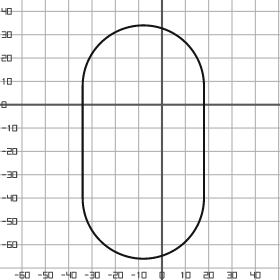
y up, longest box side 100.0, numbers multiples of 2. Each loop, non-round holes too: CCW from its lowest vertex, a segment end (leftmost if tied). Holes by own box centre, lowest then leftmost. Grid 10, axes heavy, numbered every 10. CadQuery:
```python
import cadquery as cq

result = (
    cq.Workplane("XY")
    .moveTo(-34.0, -40.0)
    .threePointArc((-8.0, -66.0), (18.0, -40.0))
    .lineTo(18.0, 8.0)
    .threePointArc((-8.0, 34.0), (-34.0, 8.0))
    .close()
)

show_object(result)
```